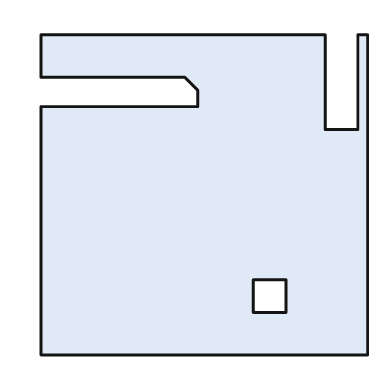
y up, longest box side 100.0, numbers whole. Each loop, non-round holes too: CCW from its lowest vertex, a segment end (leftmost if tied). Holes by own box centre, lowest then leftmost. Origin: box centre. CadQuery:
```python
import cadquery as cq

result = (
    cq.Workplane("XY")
    .moveTo(-50.0, -49.0)
    .lineTo(50.0, -49.0)
    .lineTo(50.0, 49.0)
    .lineTo(47.0, 49.0)
    .lineTo(47.0, 20.0)
    .lineTo(37.0, 20.0)
    .lineTo(37.0, 49.0)
    .lineTo(-50.0, 49.0)
    .lineTo(-50.0, 36.0)
    .lineTo(-6.0, 36.0)
    .lineTo(-2.0, 32.0)
    .lineTo(-2.0, 27.0)
    .lineTo(-50.0, 27.0)
    .close()
    .moveTo(15.0, -36.0)
    .lineTo(25.0, -36.0)
    .lineTo(25.0, -26.0)
    .lineTo(15.0, -26.0)
    .close()
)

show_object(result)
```